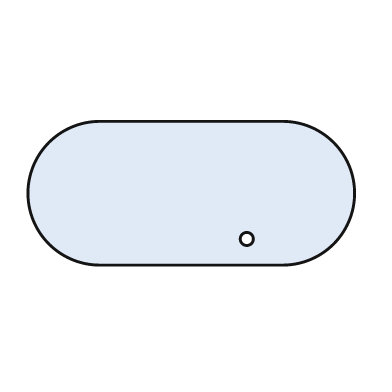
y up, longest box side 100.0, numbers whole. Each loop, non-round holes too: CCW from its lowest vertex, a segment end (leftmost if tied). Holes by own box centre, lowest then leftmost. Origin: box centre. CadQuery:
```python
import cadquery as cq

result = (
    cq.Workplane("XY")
    .moveTo(-28.0, -22.0)
    .lineTo(28.0, -22.0)
    .threePointArc((50.0, 0.0), (28.0, 22.0))
    .lineTo(-28.0, 22.0)
    .threePointArc((-50.0, 0.0), (-28.0, -22.0))
    .close()
    .moveTo(17.0, -14.0)
    .circle(2.0)
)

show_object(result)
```